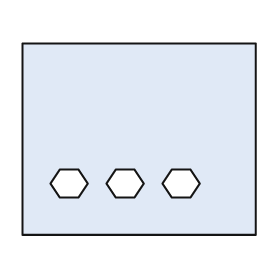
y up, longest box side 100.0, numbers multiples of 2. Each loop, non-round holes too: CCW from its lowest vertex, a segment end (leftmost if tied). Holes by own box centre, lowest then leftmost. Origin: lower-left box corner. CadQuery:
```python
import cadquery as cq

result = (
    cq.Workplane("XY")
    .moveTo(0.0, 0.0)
    .lineTo(100.0, 0.0)
    .lineTo(100.0, 82.0)
    .lineTo(0.0, 82.0)
    .close()
    .moveTo(16.0, 16.0)
    .lineTo(24.0, 16.0)
    .lineTo(28.0, 22.0)
    .lineTo(24.0, 28.0)
    .lineTo(16.0, 28.0)
    .lineTo(12.0, 22.0)
    .close()
    .moveTo(40.0, 16.0)
    .lineTo(48.0, 16.0)
    .lineTo(52.0, 22.0)
    .lineTo(48.0, 28.0)
    .lineTo(40.0, 28.0)
    .lineTo(36.0, 22.0)
    .close()
    .moveTo(64.0, 16.0)
    .lineTo(72.0, 16.0)
    .lineTo(76.0, 22.0)
    .lineTo(72.0, 28.0)
    .lineTo(64.0, 28.0)
    .lineTo(60.0, 22.0)
    .close()
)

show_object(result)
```